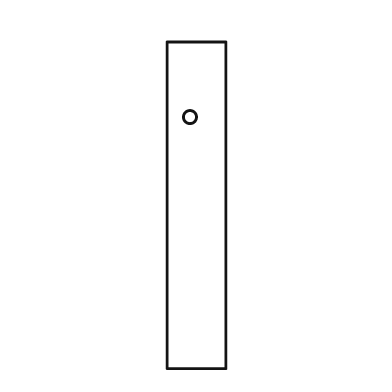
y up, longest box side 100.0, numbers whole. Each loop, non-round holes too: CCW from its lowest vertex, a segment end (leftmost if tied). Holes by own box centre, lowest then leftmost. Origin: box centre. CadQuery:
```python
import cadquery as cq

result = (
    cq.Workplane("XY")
    .moveTo(-9.0, -50.0)
    .lineTo(9.0, -50.0)
    .lineTo(9.0, 50.0)
    .lineTo(-9.0, 50.0)
    .close()
    .moveTo(-2.0, 27.0)
    .circle(2.0)
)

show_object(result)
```